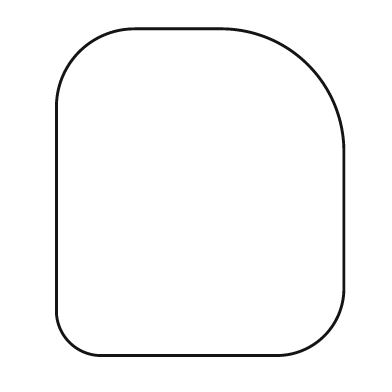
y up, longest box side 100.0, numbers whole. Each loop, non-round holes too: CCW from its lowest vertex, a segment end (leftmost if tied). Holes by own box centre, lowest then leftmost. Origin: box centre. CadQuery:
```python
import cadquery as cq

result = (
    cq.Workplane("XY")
    .moveTo(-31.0, -50.0)
    .lineTo(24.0, -50.0)
    .threePointArc((38.0, -44.0), (44.0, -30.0))
    .lineTo(44.0, 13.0)
    .threePointArc((33.0, 39.0), (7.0, 50.0))
    .lineTo(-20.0, 50.0)
    .threePointArc((-37.0, 43.0), (-44.0, 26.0))
    .lineTo(-44.0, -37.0)
    .threePointArc((-40.0, -46.0), (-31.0, -50.0))
    .close()
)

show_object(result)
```